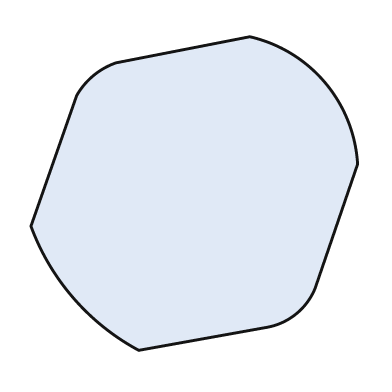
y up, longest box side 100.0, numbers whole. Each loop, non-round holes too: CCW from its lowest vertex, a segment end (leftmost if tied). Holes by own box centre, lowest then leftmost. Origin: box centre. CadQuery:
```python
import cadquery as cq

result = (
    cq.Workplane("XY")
    .moveTo(-17.0, -48.0)
    .lineTo(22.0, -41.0)
    .threePointArc((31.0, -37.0), (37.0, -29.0))
    .lineTo(50.0, 9.0)
    .threePointArc((40.0, 34.0), (17.0, 48.0))
    .lineTo(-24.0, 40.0)
    .threePointArc((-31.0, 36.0), (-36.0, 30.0))
    .lineTo(-50.0, -10.0)
    .threePointArc((-37.0, -32.0), (-17.0, -48.0))
    .close()
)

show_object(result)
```